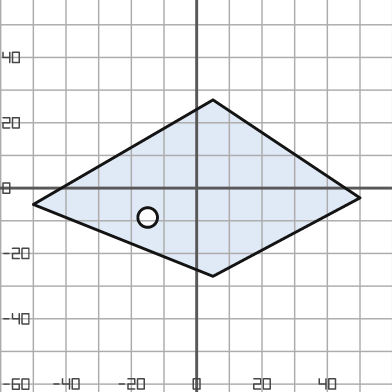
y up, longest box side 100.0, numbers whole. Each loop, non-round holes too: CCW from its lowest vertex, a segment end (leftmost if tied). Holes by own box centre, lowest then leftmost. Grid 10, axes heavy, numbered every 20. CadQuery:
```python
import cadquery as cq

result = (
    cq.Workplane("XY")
    .moveTo(5.0, -27.0)
    .lineTo(50.0, -3.0)
    .lineTo(5.0, 27.0)
    .lineTo(-50.0, -5.0)
    .close()
    .moveTo(-15.0, -9.0)
    .circle(3.0)
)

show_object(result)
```